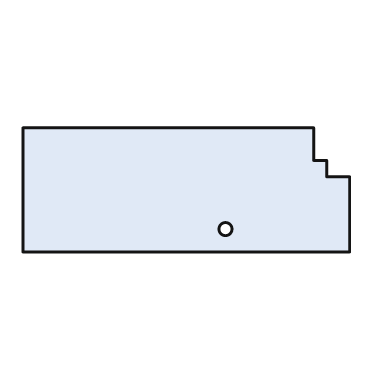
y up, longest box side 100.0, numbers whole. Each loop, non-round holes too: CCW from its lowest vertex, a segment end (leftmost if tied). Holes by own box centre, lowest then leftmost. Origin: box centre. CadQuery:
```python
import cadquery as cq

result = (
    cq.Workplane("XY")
    .moveTo(-50.0, -19.0)
    .lineTo(50.0, -19.0)
    .lineTo(50.0, 4.0)
    .lineTo(43.0, 4.0)
    .lineTo(43.0, 9.0)
    .lineTo(39.0, 9.0)
    .lineTo(39.0, 19.0)
    .lineTo(-50.0, 19.0)
    .close()
    .moveTo(12.0, -12.0)
    .circle(2.0)
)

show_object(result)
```